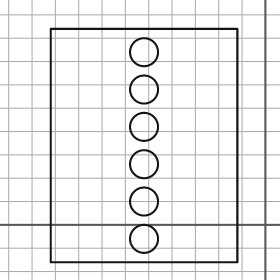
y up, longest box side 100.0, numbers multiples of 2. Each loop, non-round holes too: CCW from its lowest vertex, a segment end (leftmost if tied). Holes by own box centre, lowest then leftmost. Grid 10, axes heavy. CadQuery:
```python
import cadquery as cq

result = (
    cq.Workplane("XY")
    .moveTo(-92.0, -16.0)
    .lineTo(-12.0, -16.0)
    .lineTo(-12.0, 84.0)
    .lineTo(-92.0, 84.0)
    .close()
    .moveTo(-52.0, -6.0)
    .circle(6.0)
    .moveTo(-52.0, 10.0)
    .circle(6.0)
    .moveTo(-52.0, 26.0)
    .circle(6.0)
    .moveTo(-52.0, 42.0)
    .circle(6.0)
    .moveTo(-52.0, 58.0)
    .circle(6.0)
    .moveTo(-52.0, 74.0)
    .circle(6.0)
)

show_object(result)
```